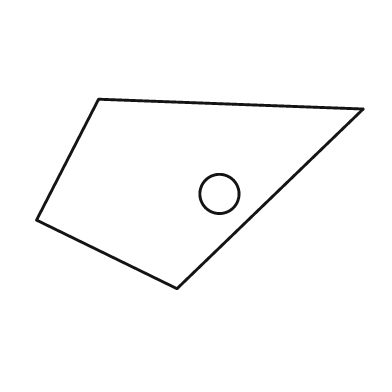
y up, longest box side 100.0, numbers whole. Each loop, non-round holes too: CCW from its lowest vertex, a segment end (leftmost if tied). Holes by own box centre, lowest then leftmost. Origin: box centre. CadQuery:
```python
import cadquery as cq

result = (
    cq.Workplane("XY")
    .moveTo(-7.0, -29.0)
    .lineTo(50.0, 26.0)
    .lineTo(-31.0, 29.0)
    .lineTo(-50.0, -8.0)
    .close()
    .moveTo(6.0, 0.0)
    .circle(6.0)
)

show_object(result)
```